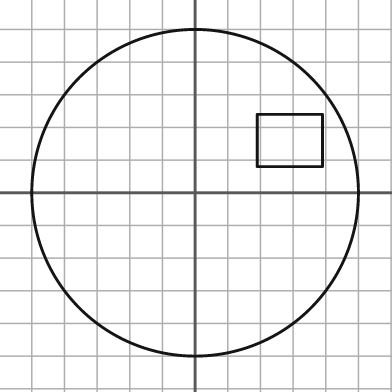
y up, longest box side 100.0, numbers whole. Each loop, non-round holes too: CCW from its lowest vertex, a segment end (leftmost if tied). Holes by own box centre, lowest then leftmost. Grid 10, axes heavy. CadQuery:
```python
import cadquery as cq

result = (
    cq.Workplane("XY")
    .moveTo(0.0, 0.0)
    .circle(50.0)
    .moveTo(19.0, 8.0)
    .lineTo(39.0, 8.0)
    .lineTo(39.0, 24.0)
    .lineTo(19.0, 24.0)
    .close()
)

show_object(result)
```